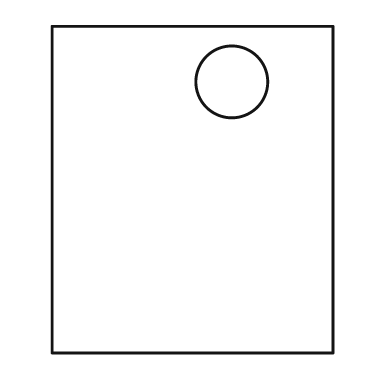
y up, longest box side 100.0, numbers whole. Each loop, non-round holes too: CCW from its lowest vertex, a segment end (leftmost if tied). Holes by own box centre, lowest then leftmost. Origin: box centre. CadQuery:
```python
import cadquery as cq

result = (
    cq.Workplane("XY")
    .moveTo(-43.0, -50.0)
    .lineTo(43.0, -50.0)
    .lineTo(43.0, 50.0)
    .lineTo(-43.0, 50.0)
    .close()
    .moveTo(12.0, 33.0)
    .circle(11.0)
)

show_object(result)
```